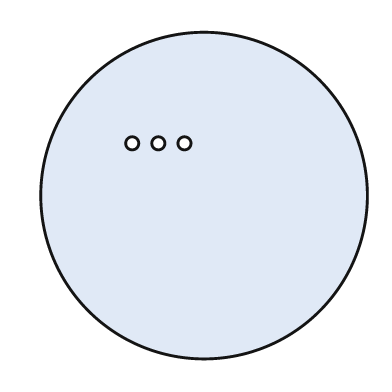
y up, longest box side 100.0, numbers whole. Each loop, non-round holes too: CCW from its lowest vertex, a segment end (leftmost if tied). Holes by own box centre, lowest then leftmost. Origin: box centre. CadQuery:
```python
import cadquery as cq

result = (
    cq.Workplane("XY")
    .moveTo(0.0, 0.0)
    .circle(50.0)
    .moveTo(-22.0, 16.0)
    .circle(2.0)
    .moveTo(-14.0, 16.0)
    .circle(2.0)
    .moveTo(-6.0, 16.0)
    .circle(2.0)
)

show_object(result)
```